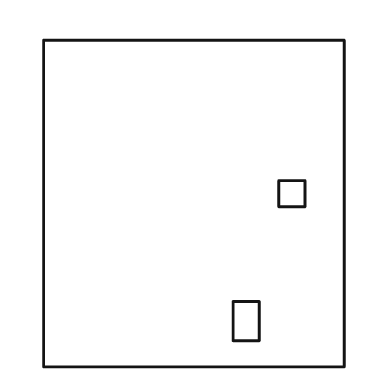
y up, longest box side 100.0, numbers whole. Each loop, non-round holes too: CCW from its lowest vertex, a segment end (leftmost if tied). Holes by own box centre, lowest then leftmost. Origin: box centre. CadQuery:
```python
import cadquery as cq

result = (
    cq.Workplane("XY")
    .moveTo(-46.0, -50.0)
    .lineTo(46.0, -50.0)
    .lineTo(46.0, 50.0)
    .lineTo(-46.0, 50.0)
    .close()
    .moveTo(12.0, -42.0)
    .lineTo(20.0, -42.0)
    .lineTo(20.0, -30.0)
    .lineTo(12.0, -30.0)
    .close()
    .moveTo(26.0, -1.0)
    .lineTo(34.0, -1.0)
    .lineTo(34.0, 7.0)
    .lineTo(26.0, 7.0)
    .close()
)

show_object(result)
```